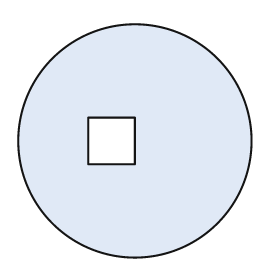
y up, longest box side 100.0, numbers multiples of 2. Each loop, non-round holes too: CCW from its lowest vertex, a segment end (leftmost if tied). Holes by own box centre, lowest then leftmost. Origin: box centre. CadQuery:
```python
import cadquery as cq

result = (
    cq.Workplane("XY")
    .moveTo(0.0, 0.0)
    .circle(50.0)
    .moveTo(-20.0, -10.0)
    .lineTo(0.0, -10.0)
    .lineTo(0.0, 10.0)
    .lineTo(-20.0, 10.0)
    .close()
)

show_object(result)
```